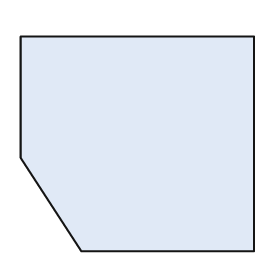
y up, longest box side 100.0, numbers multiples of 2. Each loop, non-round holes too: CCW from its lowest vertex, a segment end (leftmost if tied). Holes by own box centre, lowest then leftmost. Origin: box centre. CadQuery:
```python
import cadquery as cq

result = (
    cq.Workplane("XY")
    .moveTo(-24.0, -46.0)
    .lineTo(50.0, -46.0)
    .lineTo(50.0, 46.0)
    .lineTo(-50.0, 46.0)
    .lineTo(-50.0, -6.0)
    .close()
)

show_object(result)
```